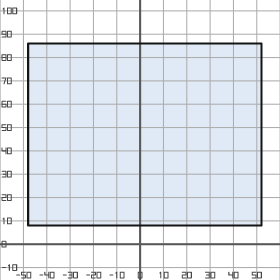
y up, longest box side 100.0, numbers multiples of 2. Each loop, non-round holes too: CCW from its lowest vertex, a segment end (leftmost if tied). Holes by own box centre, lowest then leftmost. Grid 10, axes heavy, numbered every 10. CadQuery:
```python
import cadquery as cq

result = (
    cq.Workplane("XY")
    .moveTo(-48.0, 8.0)
    .lineTo(52.0, 8.0)
    .lineTo(52.0, 86.0)
    .lineTo(-48.0, 86.0)
    .close()
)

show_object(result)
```